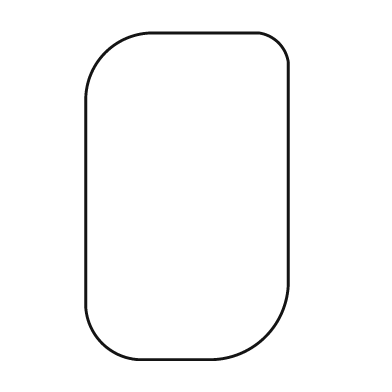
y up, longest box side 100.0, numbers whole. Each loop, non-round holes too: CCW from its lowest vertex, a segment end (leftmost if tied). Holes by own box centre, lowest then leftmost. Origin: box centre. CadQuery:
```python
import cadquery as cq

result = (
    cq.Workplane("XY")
    .moveTo(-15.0, -50.0)
    .lineTo(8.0, -50.0)
    .threePointArc((24.0, -43.0), (31.0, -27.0))
    .lineTo(31.0, 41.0)
    .threePointArc((28.0, 47.0), (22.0, 50.0))
    .lineTo(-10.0, 50.0)
    .threePointArc((-25.0, 44.0), (-31.0, 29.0))
    .lineTo(-31.0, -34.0)
    .threePointArc((-26.0, -45.0), (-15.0, -50.0))
    .close()
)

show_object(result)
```